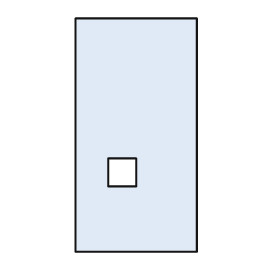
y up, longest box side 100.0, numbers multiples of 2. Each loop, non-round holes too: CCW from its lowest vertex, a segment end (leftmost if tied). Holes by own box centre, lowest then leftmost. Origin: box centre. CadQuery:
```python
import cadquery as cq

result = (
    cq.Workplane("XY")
    .moveTo(-26.0, -50.0)
    .lineTo(26.0, -50.0)
    .lineTo(26.0, 50.0)
    .lineTo(-26.0, 50.0)
    .close()
    .moveTo(-12.0, -22.0)
    .lineTo(0.0, -22.0)
    .lineTo(0.0, -10.0)
    .lineTo(-12.0, -10.0)
    .close()
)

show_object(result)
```